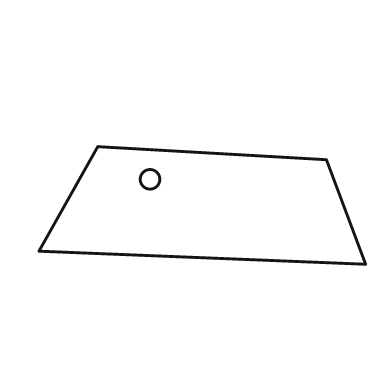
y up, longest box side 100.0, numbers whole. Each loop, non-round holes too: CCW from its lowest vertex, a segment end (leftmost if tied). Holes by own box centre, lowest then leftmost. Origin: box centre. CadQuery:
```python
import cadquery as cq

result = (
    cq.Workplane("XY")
    .moveTo(50.0, -18.0)
    .lineTo(38.0, 14.0)
    .lineTo(-32.0, 18.0)
    .lineTo(-50.0, -14.0)
    .close()
    .moveTo(-16.0, 8.0)
    .circle(3.0)
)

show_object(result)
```